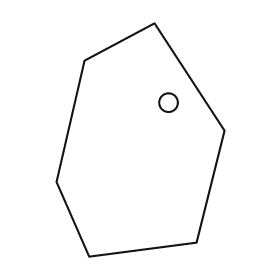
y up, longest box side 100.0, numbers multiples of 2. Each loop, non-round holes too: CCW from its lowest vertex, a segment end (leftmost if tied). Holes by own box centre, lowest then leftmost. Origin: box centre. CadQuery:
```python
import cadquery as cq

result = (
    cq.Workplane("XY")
    .moveTo(-22.0, -50.0)
    .lineTo(24.0, -44.0)
    .lineTo(36.0, 4.0)
    .lineTo(6.0, 50.0)
    .lineTo(-24.0, 34.0)
    .lineTo(-36.0, -18.0)
    .close()
    .moveTo(12.0, 16.0)
    .circle(4.0)
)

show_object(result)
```